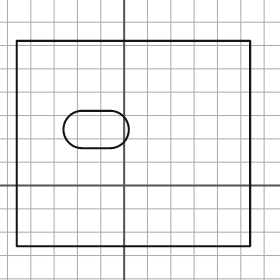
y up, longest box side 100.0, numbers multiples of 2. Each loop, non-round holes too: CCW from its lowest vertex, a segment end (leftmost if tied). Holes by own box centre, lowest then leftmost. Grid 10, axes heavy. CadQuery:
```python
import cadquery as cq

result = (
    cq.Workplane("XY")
    .moveTo(-46.0, -26.0)
    .lineTo(54.0, -26.0)
    .lineTo(54.0, 62.0)
    .lineTo(-46.0, 62.0)
    .close()
    .moveTo(-18.0, 16.0)
    .lineTo(-6.0, 16.0)
    .threePointArc((2.0, 24.0), (-6.0, 32.0))
    .lineTo(-18.0, 32.0)
    .threePointArc((-26.0, 24.0), (-18.0, 16.0))
    .close()
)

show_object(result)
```